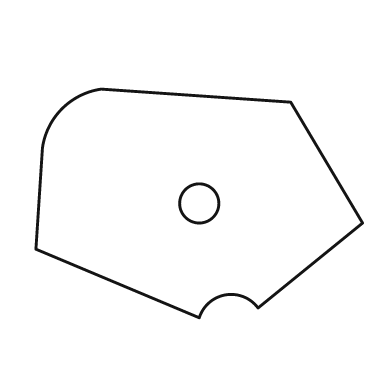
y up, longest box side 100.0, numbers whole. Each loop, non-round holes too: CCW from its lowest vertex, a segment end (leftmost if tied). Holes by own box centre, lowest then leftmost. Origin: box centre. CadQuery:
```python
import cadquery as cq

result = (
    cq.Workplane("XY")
    .moveTo(0.0, -35.0)
    .threePointArc((8.0, -28.0), (18.0, -32.0))
    .lineTo(50.0, -6.0)
    .lineTo(28.0, 31.0)
    .lineTo(-30.0, 35.0)
    .threePointArc((-42.0, 29.0), (-48.0, 17.0))
    .lineTo(-50.0, -14.0)
    .close()
    .moveTo(0.0, 0.0)
    .circle(6.0)
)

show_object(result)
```